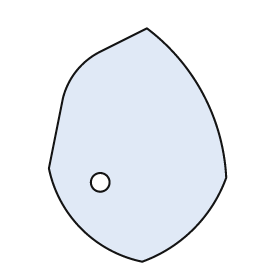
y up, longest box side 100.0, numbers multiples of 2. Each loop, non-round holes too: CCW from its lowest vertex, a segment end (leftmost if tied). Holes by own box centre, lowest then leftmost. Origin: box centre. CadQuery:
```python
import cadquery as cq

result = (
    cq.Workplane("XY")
    .moveTo(2.0, -50.0)
    .threePointArc((24.0, -36.0), (38.0, -14.0))
    .threePointArc((28.0, 22.0), (4.0, 50.0))
    .lineTo(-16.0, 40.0)
    .threePointArc((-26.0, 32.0), (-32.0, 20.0))
    .lineTo(-38.0, -10.0)
    .threePointArc((-24.0, -36.0), (2.0, -50.0))
    .close()
    .moveTo(-16.0, -16.0)
    .circle(4.0)
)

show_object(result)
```